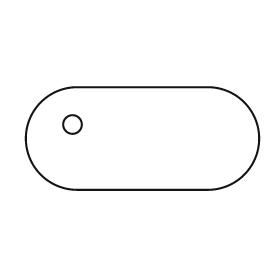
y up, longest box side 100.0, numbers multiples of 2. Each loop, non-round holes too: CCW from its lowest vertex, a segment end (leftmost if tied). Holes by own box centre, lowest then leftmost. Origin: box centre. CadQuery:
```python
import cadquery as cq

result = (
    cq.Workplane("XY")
    .moveTo(-28.0, -22.0)
    .lineTo(28.0, -22.0)
    .threePointArc((50.0, 0.0), (28.0, 22.0))
    .lineTo(-28.0, 22.0)
    .threePointArc((-50.0, 0.0), (-28.0, -22.0))
    .close()
    .moveTo(-30.0, 6.0)
    .circle(4.0)
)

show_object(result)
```